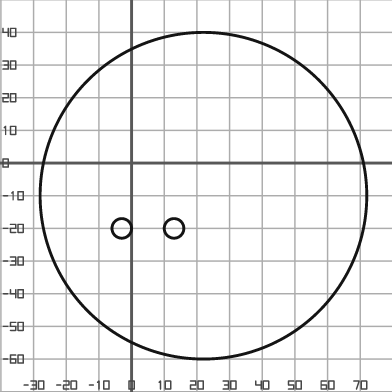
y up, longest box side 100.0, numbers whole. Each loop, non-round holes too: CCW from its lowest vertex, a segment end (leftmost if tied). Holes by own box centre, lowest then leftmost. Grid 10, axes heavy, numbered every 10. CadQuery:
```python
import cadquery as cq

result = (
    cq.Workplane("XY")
    .moveTo(22.0, -10.0)
    .circle(50.0)
    .moveTo(-3.0, -20.0)
    .circle(3.0)
    .moveTo(13.0, -20.0)
    .circle(3.0)
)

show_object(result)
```